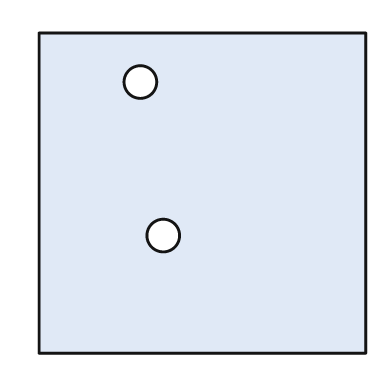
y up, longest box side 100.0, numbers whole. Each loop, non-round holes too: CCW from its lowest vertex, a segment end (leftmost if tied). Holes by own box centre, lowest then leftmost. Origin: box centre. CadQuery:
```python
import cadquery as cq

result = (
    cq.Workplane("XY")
    .moveTo(-50.0, -49.0)
    .lineTo(50.0, -49.0)
    .lineTo(50.0, 49.0)
    .lineTo(-50.0, 49.0)
    .close()
    .moveTo(-12.0, -13.0)
    .circle(5.0)
    .moveTo(-19.0, 34.0)
    .circle(5.0)
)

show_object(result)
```